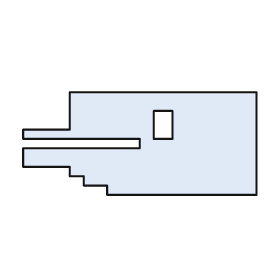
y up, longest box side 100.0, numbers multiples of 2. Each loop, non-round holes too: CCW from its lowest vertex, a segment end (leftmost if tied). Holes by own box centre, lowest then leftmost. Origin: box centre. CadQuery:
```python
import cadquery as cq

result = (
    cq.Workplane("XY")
    .moveTo(-14.0, -22.0)
    .lineTo(50.0, -22.0)
    .lineTo(50.0, 22.0)
    .lineTo(-30.0, 22.0)
    .lineTo(-30.0, 6.0)
    .lineTo(-50.0, 6.0)
    .lineTo(-50.0, 2.0)
    .lineTo(0.0, 2.0)
    .lineTo(0.0, -2.0)
    .lineTo(-50.0, -2.0)
    .lineTo(-50.0, -10.0)
    .lineTo(-30.0, -10.0)
    .lineTo(-30.0, -14.0)
    .lineTo(-24.0, -14.0)
    .lineTo(-24.0, -18.0)
    .lineTo(-14.0, -18.0)
    .close()
    .moveTo(6.0, 2.0)
    .lineTo(14.0, 2.0)
    .lineTo(14.0, 14.0)
    .lineTo(6.0, 14.0)
    .close()
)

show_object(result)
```